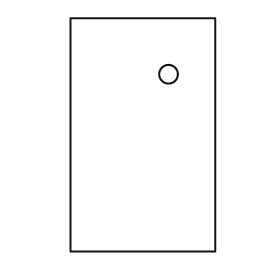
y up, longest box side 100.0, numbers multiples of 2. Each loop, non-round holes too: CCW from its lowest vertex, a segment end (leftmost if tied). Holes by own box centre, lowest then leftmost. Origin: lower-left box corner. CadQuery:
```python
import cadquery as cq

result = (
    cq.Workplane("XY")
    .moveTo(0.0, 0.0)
    .lineTo(62.0, 0.0)
    .lineTo(62.0, 100.0)
    .lineTo(0.0, 100.0)
    .close()
    .moveTo(42.0, 76.0)
    .circle(4.0)
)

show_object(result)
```